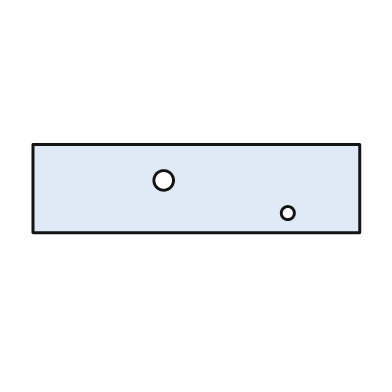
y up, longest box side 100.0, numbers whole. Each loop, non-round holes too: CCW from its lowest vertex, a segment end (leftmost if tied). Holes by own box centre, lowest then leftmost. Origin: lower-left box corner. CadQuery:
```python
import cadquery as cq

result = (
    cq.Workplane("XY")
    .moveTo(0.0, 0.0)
    .lineTo(100.0, 0.0)
    .lineTo(100.0, 27.0)
    .lineTo(0.0, 27.0)
    .close()
    .moveTo(78.0, 6.0)
    .circle(2.0)
    .moveTo(40.0, 16.0)
    .circle(3.0)
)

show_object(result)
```